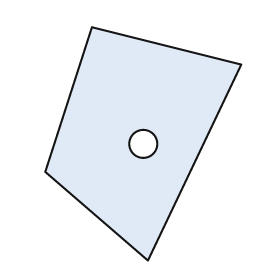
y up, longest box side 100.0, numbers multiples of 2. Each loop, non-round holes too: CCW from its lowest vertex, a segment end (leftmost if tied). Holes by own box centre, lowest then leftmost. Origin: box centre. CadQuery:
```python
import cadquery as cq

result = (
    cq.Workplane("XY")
    .moveTo(2.0, -50.0)
    .lineTo(42.0, 34.0)
    .lineTo(-22.0, 50.0)
    .lineTo(-42.0, -12.0)
    .close()
    .moveTo(0.0, 0.0)
    .circle(6.0)
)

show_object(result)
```